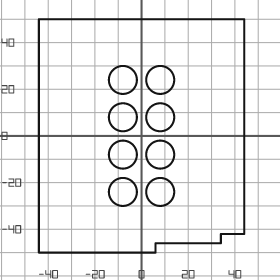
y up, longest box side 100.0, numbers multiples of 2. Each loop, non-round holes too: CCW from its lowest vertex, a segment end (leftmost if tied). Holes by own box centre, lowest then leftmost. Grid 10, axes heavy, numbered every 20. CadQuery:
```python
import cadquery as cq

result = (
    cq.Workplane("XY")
    .moveTo(-44.0, -50.0)
    .lineTo(6.0, -50.0)
    .lineTo(6.0, -46.0)
    .lineTo(34.0, -46.0)
    .lineTo(34.0, -42.0)
    .lineTo(44.0, -42.0)
    .lineTo(44.0, 50.0)
    .lineTo(-44.0, 50.0)
    .close()
    .moveTo(-8.0, -24.0)
    .circle(6.0)
    .moveTo(8.0, -24.0)
    .circle(6.0)
    .moveTo(-8.0, -8.0)
    .circle(6.0)
    .moveTo(8.0, -8.0)
    .circle(6.0)
    .moveTo(-8.0, 8.0)
    .circle(6.0)
    .moveTo(8.0, 8.0)
    .circle(6.0)
    .moveTo(-8.0, 24.0)
    .circle(6.0)
    .moveTo(8.0, 24.0)
    .circle(6.0)
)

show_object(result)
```